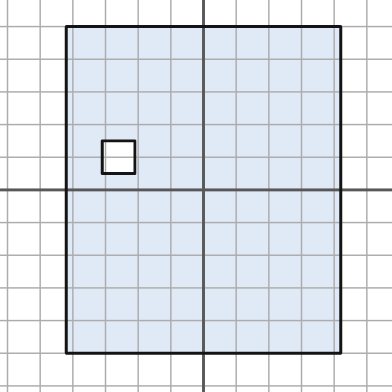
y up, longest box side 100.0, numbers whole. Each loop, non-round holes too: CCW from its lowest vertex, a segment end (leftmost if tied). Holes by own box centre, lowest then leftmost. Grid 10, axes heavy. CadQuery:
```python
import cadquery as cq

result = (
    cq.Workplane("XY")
    .moveTo(-42.0, -50.0)
    .lineTo(42.0, -50.0)
    .lineTo(42.0, 50.0)
    .lineTo(-42.0, 50.0)
    .close()
    .moveTo(-31.0, 5.0)
    .lineTo(-21.0, 5.0)
    .lineTo(-21.0, 15.0)
    .lineTo(-31.0, 15.0)
    .close()
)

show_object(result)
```